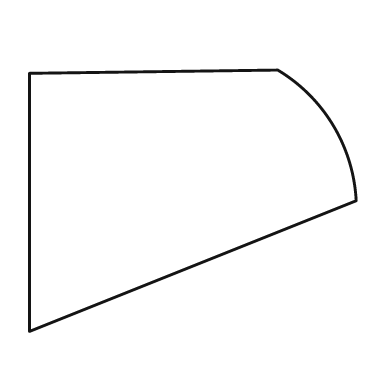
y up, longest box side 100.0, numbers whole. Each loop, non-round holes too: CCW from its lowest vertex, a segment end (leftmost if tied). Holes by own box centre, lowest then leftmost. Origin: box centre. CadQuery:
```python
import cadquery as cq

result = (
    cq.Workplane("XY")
    .moveTo(-50.0, -40.0)
    .lineTo(50.0, 0.0)
    .threePointArc((43.0, 23.0), (26.0, 40.0))
    .lineTo(-50.0, 39.0)
    .close()
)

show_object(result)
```